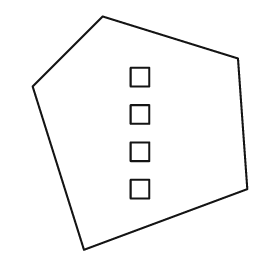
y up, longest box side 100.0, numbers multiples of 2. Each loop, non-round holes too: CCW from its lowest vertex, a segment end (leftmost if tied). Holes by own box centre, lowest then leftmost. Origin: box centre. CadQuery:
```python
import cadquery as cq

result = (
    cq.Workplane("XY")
    .moveTo(-24.0, -50.0)
    .lineTo(46.0, -24.0)
    .lineTo(42.0, 32.0)
    .lineTo(-16.0, 50.0)
    .lineTo(-46.0, 20.0)
    .close()
    .moveTo(-4.0, -28.0)
    .lineTo(4.0, -28.0)
    .lineTo(4.0, -20.0)
    .lineTo(-4.0, -20.0)
    .close()
    .moveTo(-4.0, -12.0)
    .lineTo(4.0, -12.0)
    .lineTo(4.0, -4.0)
    .lineTo(-4.0, -4.0)
    .close()
    .moveTo(-4.0, 4.0)
    .lineTo(4.0, 4.0)
    .lineTo(4.0, 12.0)
    .lineTo(-4.0, 12.0)
    .close()
    .moveTo(-4.0, 20.0)
    .lineTo(4.0, 20.0)
    .lineTo(4.0, 28.0)
    .lineTo(-4.0, 28.0)
    .close()
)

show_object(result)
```